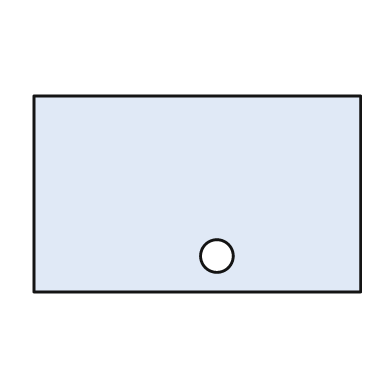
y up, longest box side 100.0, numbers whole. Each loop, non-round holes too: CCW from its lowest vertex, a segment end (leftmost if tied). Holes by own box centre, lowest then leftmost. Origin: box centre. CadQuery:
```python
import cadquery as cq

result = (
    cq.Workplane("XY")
    .moveTo(-50.0, -30.0)
    .lineTo(50.0, -30.0)
    .lineTo(50.0, 30.0)
    .lineTo(-50.0, 30.0)
    .close()
    .moveTo(6.0, -19.0)
    .circle(5.0)
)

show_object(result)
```